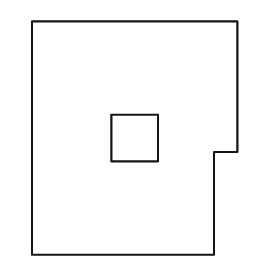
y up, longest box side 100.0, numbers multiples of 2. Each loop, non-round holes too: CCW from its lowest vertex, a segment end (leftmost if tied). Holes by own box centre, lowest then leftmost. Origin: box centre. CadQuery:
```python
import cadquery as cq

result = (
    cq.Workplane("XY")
    .moveTo(-44.0, -50.0)
    .lineTo(34.0, -50.0)
    .lineTo(34.0, -6.0)
    .lineTo(44.0, -6.0)
    .lineTo(44.0, 50.0)
    .lineTo(-44.0, 50.0)
    .close()
    .moveTo(-10.0, -10.0)
    .lineTo(10.0, -10.0)
    .lineTo(10.0, 10.0)
    .lineTo(-10.0, 10.0)
    .close()
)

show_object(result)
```